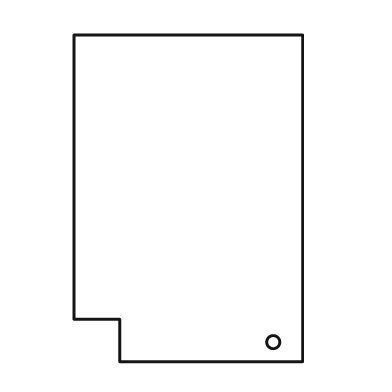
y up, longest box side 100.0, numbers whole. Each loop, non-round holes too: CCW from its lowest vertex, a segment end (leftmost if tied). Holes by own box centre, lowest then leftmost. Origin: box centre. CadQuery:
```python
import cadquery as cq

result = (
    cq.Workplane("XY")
    .moveTo(-21.0, -50.0)
    .lineTo(35.0, -50.0)
    .lineTo(35.0, 50.0)
    .lineTo(-35.0, 50.0)
    .lineTo(-35.0, -37.0)
    .lineTo(-21.0, -37.0)
    .close()
    .moveTo(26.0, -44.0)
    .circle(2.0)
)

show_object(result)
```